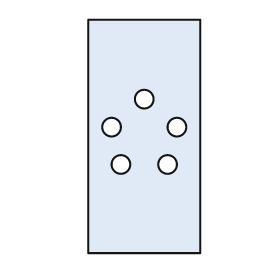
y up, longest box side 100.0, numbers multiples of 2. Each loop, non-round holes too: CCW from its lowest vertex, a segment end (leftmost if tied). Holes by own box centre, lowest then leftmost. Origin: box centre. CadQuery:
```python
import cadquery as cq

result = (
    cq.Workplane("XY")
    .moveTo(-24.0, -50.0)
    .lineTo(24.0, -50.0)
    .lineTo(24.0, 50.0)
    .lineTo(-24.0, 50.0)
    .close()
    .moveTo(-10.0, -12.0)
    .circle(4.0)
    .moveTo(10.0, -12.0)
    .circle(4.0)
    .moveTo(-14.0, 4.0)
    .circle(4.0)
    .moveTo(14.0, 4.0)
    .circle(4.0)
    .moveTo(0.0, 16.0)
    .circle(4.0)
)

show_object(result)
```